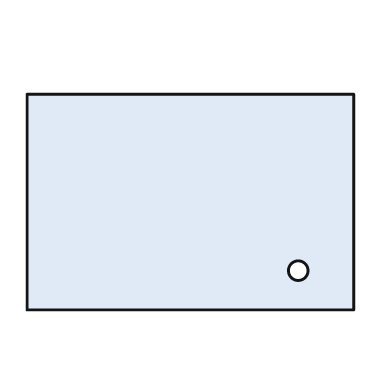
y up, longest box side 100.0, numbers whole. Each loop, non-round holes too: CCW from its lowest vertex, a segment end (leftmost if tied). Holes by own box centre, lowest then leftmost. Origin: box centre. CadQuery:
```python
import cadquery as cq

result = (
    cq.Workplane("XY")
    .moveTo(-50.0, -33.0)
    .lineTo(50.0, -33.0)
    .lineTo(50.0, 33.0)
    .lineTo(-50.0, 33.0)
    .close()
    .moveTo(33.0, -21.0)
    .circle(3.0)
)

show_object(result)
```